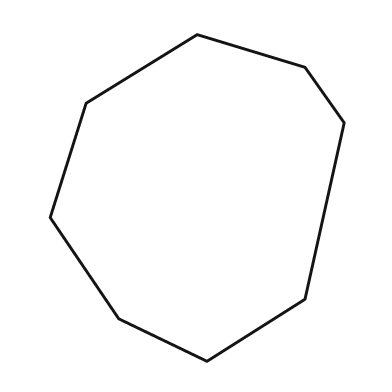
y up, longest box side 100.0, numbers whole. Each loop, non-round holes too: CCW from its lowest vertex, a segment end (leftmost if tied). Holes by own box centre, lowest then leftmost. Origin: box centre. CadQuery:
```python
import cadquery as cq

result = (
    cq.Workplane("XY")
    .moveTo(3.0, -50.0)
    .lineTo(33.0, -31.0)
    .lineTo(45.0, 23.0)
    .lineTo(33.0, 40.0)
    .lineTo(0.0, 50.0)
    .lineTo(-34.0, 29.0)
    .lineTo(-45.0, -6.0)
    .lineTo(-24.0, -37.0)
    .close()
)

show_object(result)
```